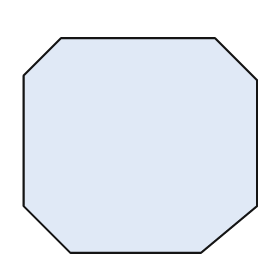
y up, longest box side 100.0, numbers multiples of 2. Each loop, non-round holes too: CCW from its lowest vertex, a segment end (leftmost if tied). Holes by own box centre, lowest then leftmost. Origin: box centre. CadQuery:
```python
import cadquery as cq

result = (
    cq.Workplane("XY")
    .moveTo(-30.0, -46.0)
    .lineTo(26.0, -46.0)
    .lineTo(50.0, -26.0)
    .lineTo(50.0, 28.0)
    .lineTo(32.0, 46.0)
    .lineTo(-34.0, 46.0)
    .lineTo(-50.0, 30.0)
    .lineTo(-50.0, -26.0)
    .close()
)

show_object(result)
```